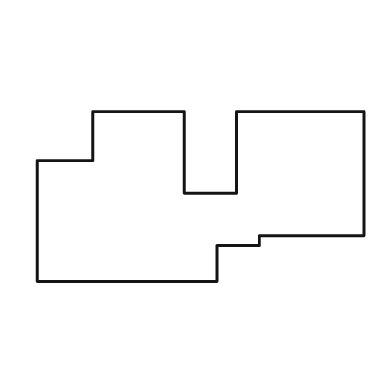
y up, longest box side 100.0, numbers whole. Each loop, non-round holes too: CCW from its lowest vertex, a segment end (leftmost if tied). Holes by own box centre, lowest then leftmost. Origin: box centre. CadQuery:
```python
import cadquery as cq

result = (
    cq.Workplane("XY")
    .moveTo(-50.0, -26.0)
    .lineTo(5.0, -26.0)
    .lineTo(5.0, -15.0)
    .lineTo(18.0, -15.0)
    .lineTo(18.0, -12.0)
    .lineTo(50.0, -12.0)
    .lineTo(50.0, 26.0)
    .lineTo(11.0, 26.0)
    .lineTo(11.0, 1.0)
    .lineTo(-5.0, 1.0)
    .lineTo(-5.0, 26.0)
    .lineTo(-33.0, 26.0)
    .lineTo(-33.0, 11.0)
    .lineTo(-50.0, 11.0)
    .close()
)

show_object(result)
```